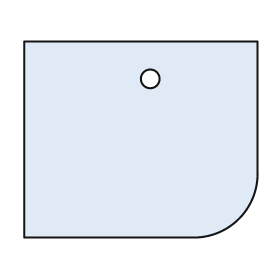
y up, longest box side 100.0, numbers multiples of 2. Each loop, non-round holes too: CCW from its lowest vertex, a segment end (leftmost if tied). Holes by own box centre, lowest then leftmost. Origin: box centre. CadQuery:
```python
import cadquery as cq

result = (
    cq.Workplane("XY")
    .moveTo(-50.0, -42.0)
    .lineTo(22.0, -42.0)
    .threePointArc((42.0, -34.0), (50.0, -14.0))
    .lineTo(50.0, 42.0)
    .lineTo(-50.0, 42.0)
    .close()
    .moveTo(4.0, 26.0)
    .circle(4.0)
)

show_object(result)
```